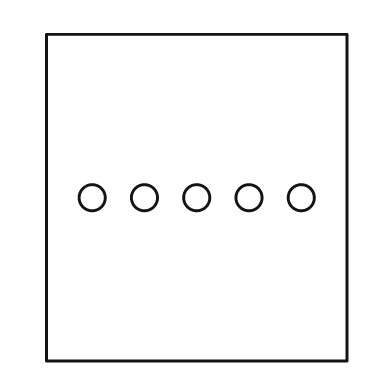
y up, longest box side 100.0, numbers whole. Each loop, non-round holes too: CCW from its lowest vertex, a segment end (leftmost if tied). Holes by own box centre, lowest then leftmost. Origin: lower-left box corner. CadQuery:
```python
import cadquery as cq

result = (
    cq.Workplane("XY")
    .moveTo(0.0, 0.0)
    .lineTo(92.0, 0.0)
    .lineTo(92.0, 100.0)
    .lineTo(0.0, 100.0)
    .close()
    .moveTo(14.0, 50.0)
    .circle(4.0)
    .moveTo(30.0, 50.0)
    .circle(4.0)
    .moveTo(46.0, 50.0)
    .circle(4.0)
    .moveTo(62.0, 50.0)
    .circle(4.0)
    .moveTo(78.0, 50.0)
    .circle(4.0)
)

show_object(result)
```